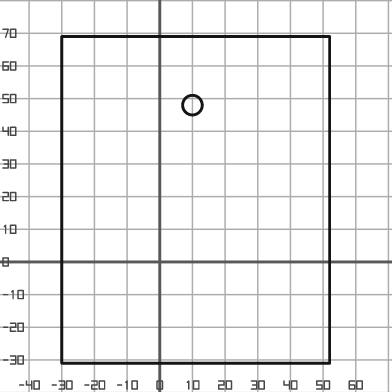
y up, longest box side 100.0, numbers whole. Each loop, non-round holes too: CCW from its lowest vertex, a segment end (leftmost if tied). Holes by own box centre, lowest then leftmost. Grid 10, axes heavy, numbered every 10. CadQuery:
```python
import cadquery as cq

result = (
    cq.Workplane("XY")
    .moveTo(-30.0, -31.0)
    .lineTo(52.0, -31.0)
    .lineTo(52.0, 69.0)
    .lineTo(-30.0, 69.0)
    .close()
    .moveTo(10.0, 48.0)
    .circle(3.0)
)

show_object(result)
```